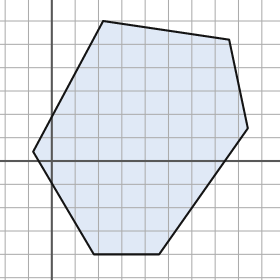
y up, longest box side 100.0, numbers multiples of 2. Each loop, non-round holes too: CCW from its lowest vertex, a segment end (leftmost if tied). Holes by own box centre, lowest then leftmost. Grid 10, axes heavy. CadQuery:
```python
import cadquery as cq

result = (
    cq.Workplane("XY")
    .moveTo(18.0, -40.0)
    .lineTo(46.0, -40.0)
    .lineTo(84.0, 14.0)
    .lineTo(76.0, 52.0)
    .lineTo(22.0, 60.0)
    .lineTo(-8.0, 4.0)
    .close()
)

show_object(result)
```